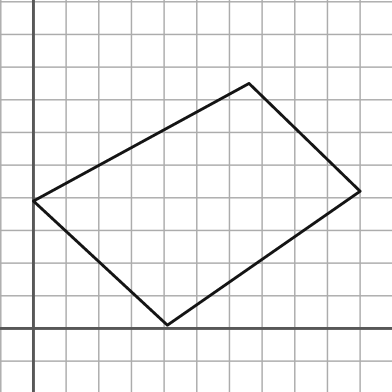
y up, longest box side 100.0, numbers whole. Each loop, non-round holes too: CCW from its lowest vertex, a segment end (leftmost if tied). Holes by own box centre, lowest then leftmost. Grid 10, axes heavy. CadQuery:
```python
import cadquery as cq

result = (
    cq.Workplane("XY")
    .moveTo(41.0, 1.0)
    .lineTo(100.0, 42.0)
    .lineTo(66.0, 75.0)
    .lineTo(0.0, 39.0)
    .close()
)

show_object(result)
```